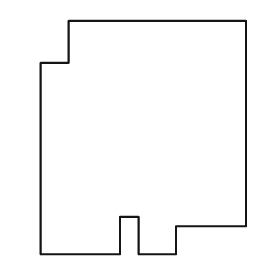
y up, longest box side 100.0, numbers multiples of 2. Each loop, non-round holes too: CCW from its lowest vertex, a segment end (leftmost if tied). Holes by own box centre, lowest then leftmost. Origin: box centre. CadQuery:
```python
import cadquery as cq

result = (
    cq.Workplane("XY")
    .moveTo(-44.0, -50.0)
    .lineTo(-10.0, -50.0)
    .lineTo(-10.0, -34.0)
    .lineTo(-2.0, -34.0)
    .lineTo(-2.0, -50.0)
    .lineTo(14.0, -50.0)
    .lineTo(14.0, -38.0)
    .lineTo(44.0, -38.0)
    .lineTo(44.0, 50.0)
    .lineTo(-32.0, 50.0)
    .lineTo(-32.0, 32.0)
    .lineTo(-44.0, 32.0)
    .close()
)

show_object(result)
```